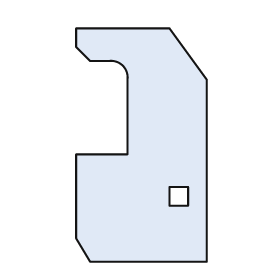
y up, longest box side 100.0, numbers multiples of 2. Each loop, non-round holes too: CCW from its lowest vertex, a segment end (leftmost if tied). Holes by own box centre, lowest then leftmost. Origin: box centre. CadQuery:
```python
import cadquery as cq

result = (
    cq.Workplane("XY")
    .moveTo(-22.0, -50.0)
    .lineTo(28.0, -50.0)
    .lineTo(28.0, 28.0)
    .lineTo(12.0, 50.0)
    .lineTo(-28.0, 50.0)
    .lineTo(-28.0, 42.0)
    .lineTo(-22.0, 36.0)
    .lineTo(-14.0, 36.0)
    .threePointArc((-8.0, 34.0), (-6.0, 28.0))
    .lineTo(-6.0, -4.0)
    .lineTo(-28.0, -4.0)
    .lineTo(-28.0, -40.0)
    .close()
    .moveTo(12.0, -26.0)
    .lineTo(20.0, -26.0)
    .lineTo(20.0, -18.0)
    .lineTo(12.0, -18.0)
    .close()
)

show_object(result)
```